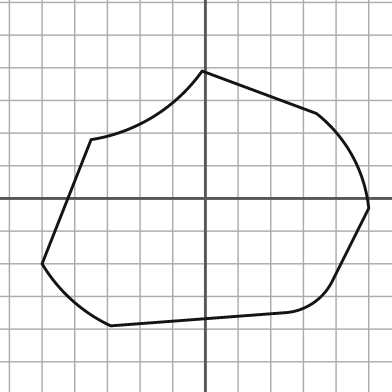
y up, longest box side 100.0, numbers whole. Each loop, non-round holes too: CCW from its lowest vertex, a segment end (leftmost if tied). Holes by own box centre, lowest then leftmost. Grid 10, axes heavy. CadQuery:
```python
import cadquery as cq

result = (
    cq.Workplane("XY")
    .moveTo(-29.0, -39.0)
    .lineTo(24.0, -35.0)
    .threePointArc((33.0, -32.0), (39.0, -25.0))
    .lineTo(50.0, -3.0)
    .threePointArc((45.0, 13.0), (34.0, 26.0))
    .lineTo(-1.0, 39.0)
    .threePointArc((-16.0, 25.0), (-35.0, 18.0))
    .lineTo(-50.0, -20.0)
    .threePointArc((-41.0, -31.0), (-29.0, -39.0))
    .close()
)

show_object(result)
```